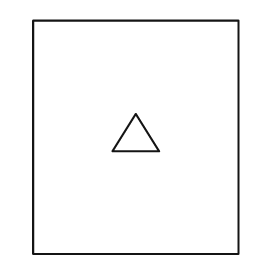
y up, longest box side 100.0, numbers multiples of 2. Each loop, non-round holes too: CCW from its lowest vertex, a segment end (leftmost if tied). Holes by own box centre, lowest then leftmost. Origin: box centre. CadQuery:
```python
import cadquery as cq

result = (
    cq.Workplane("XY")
    .moveTo(-44.0, -50.0)
    .lineTo(44.0, -50.0)
    .lineTo(44.0, 50.0)
    .lineTo(-44.0, 50.0)
    .close()
    .moveTo(-10.0, -6.0)
    .lineTo(10.0, -6.0)
    .lineTo(0.0, 10.0)
    .close()
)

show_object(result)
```